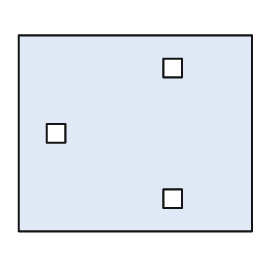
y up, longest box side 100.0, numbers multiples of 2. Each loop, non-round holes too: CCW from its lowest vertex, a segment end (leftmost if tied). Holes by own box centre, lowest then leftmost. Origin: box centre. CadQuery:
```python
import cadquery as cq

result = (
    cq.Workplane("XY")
    .moveTo(-50.0, -42.0)
    .lineTo(50.0, -42.0)
    .lineTo(50.0, 42.0)
    .lineTo(-50.0, 42.0)
    .close()
    .moveTo(12.0, -32.0)
    .lineTo(20.0, -32.0)
    .lineTo(20.0, -24.0)
    .lineTo(12.0, -24.0)
    .close()
    .moveTo(-38.0, -4.0)
    .lineTo(-30.0, -4.0)
    .lineTo(-30.0, 4.0)
    .lineTo(-38.0, 4.0)
    .close()
    .moveTo(12.0, 24.0)
    .lineTo(20.0, 24.0)
    .lineTo(20.0, 32.0)
    .lineTo(12.0, 32.0)
    .close()
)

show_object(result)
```